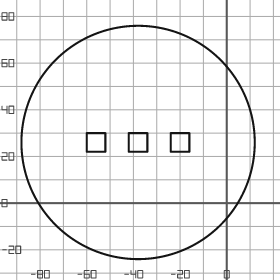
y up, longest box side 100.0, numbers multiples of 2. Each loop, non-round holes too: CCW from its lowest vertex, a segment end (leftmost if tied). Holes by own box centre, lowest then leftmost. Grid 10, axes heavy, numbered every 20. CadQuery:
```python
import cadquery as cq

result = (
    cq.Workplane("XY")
    .moveTo(-38.0, 26.0)
    .circle(50.0)
    .moveTo(-60.0, 22.0)
    .lineTo(-52.0, 22.0)
    .lineTo(-52.0, 30.0)
    .lineTo(-60.0, 30.0)
    .close()
    .moveTo(-42.0, 22.0)
    .lineTo(-34.0, 22.0)
    .lineTo(-34.0, 30.0)
    .lineTo(-42.0, 30.0)
    .close()
    .moveTo(-24.0, 22.0)
    .lineTo(-16.0, 22.0)
    .lineTo(-16.0, 30.0)
    .lineTo(-24.0, 30.0)
    .close()
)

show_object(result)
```